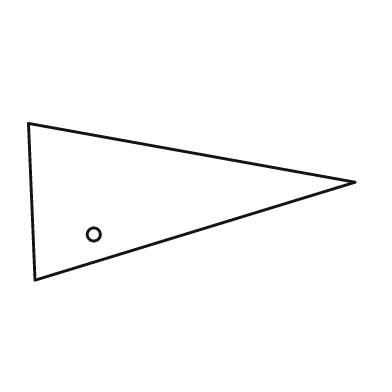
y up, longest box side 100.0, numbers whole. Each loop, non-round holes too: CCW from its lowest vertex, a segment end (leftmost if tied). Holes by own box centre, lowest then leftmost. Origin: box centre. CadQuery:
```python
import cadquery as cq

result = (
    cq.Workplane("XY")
    .moveTo(-48.0, -24.0)
    .lineTo(50.0, 6.0)
    .lineTo(-50.0, 24.0)
    .close()
    .moveTo(-30.0, -10.0)
    .circle(2.0)
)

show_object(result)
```